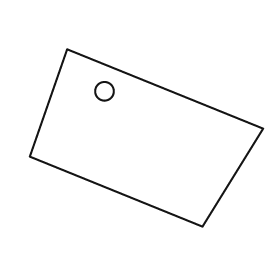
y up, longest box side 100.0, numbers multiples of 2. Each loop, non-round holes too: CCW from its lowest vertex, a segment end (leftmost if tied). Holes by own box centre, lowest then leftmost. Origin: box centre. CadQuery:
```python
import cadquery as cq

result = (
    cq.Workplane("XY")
    .moveTo(24.0, -38.0)
    .lineTo(50.0, 4.0)
    .lineTo(-34.0, 38.0)
    .lineTo(-50.0, -8.0)
    .close()
    .moveTo(-18.0, 20.0)
    .circle(4.0)
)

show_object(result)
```